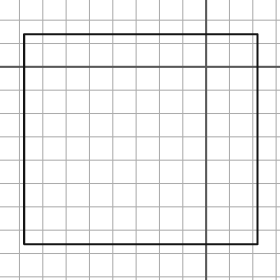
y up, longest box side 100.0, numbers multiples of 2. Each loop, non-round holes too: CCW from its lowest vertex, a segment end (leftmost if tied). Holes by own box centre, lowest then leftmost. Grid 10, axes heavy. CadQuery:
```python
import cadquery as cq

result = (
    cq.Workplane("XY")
    .moveTo(-78.0, -76.0)
    .lineTo(22.0, -76.0)
    .lineTo(22.0, 14.0)
    .lineTo(-78.0, 14.0)
    .close()
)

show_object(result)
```